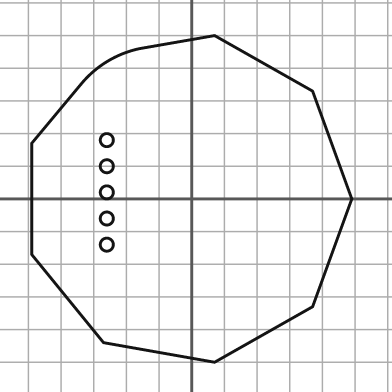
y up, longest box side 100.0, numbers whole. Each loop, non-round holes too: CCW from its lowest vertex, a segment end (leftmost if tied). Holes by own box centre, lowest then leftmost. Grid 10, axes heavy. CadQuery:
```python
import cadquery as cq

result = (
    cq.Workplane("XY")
    .moveTo(7.0, -50.0)
    .lineTo(37.0, -33.0)
    .lineTo(49.0, 0.0)
    .lineTo(37.0, 33.0)
    .lineTo(7.0, 50.0)
    .lineTo(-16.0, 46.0)
    .threePointArc((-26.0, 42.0), (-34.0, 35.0))
    .lineTo(-49.0, 17.0)
    .lineTo(-49.0, -17.0)
    .lineTo(-27.0, -44.0)
    .close()
    .moveTo(-26.0, -14.0)
    .circle(2.0)
    .moveTo(-26.0, -6.0)
    .circle(2.0)
    .moveTo(-26.0, 2.0)
    .circle(2.0)
    .moveTo(-26.0, 10.0)
    .circle(2.0)
    .moveTo(-26.0, 18.0)
    .circle(2.0)
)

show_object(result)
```